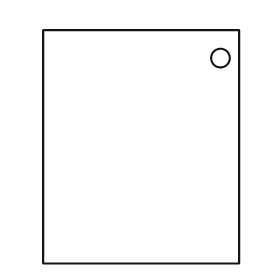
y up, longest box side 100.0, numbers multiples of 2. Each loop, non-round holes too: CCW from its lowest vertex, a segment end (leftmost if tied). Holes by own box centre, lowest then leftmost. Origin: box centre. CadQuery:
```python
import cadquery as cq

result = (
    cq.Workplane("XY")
    .moveTo(-42.0, -50.0)
    .lineTo(42.0, -50.0)
    .lineTo(42.0, 50.0)
    .lineTo(-42.0, 50.0)
    .close()
    .moveTo(34.0, 38.0)
    .circle(4.0)
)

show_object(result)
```